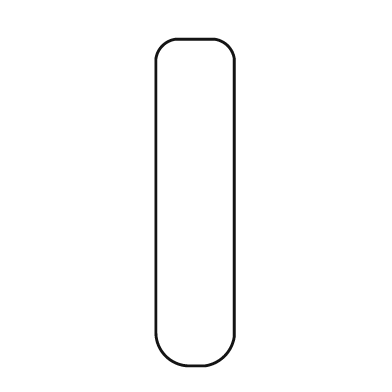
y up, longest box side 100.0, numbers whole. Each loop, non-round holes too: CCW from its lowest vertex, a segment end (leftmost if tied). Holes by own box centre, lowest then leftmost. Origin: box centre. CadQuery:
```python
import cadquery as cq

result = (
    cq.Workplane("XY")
    .moveTo(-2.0, -50.0)
    .lineTo(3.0, -50.0)
    .threePointArc((9.0, -47.0), (12.0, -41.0))
    .lineTo(12.0, 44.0)
    .threePointArc((10.0, 48.0), (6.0, 50.0))
    .lineTo(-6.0, 50.0)
    .threePointArc((-10.0, 48.0), (-12.0, 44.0))
    .lineTo(-12.0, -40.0)
    .threePointArc((-9.0, -47.0), (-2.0, -50.0))
    .close()
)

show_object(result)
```